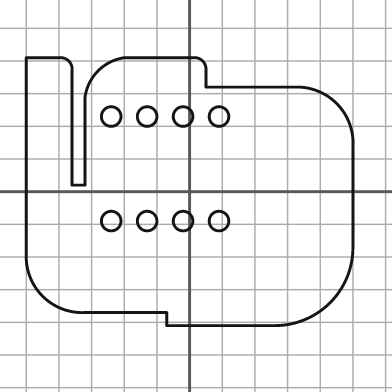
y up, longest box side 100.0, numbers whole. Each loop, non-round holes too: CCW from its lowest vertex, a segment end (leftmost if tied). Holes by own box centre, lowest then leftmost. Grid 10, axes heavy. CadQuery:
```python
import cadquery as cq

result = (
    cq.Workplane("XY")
    .moveTo(-7.0, -41.0)
    .lineTo(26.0, -41.0)
    .threePointArc((43.0, -34.0), (50.0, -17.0))
    .lineTo(50.0, 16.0)
    .threePointArc((45.0, 27.0), (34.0, 32.0))
    .lineTo(5.0, 32.0)
    .lineTo(5.0, 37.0)
    .threePointArc((4.0, 40.0), (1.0, 41.0))
    .lineTo(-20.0, 41.0)
    .threePointArc((-28.0, 37.0), (-32.0, 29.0))
    .lineTo(-32.0, 2.0)
    .lineTo(-36.0, 2.0)
    .lineTo(-36.0, 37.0)
    .threePointArc((-37.0, 40.0), (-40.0, 41.0))
    .lineTo(-50.0, 41.0)
    .lineTo(-50.0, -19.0)
    .threePointArc((-45.0, -32.0), (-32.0, -37.0))
    .lineTo(-7.0, -37.0)
    .close()
    .moveTo(-24.0, -9.0)
    .circle(3.0)
    .moveTo(-13.0, -9.0)
    .circle(3.0)
    .moveTo(-2.0, -9.0)
    .circle(3.0)
    .moveTo(9.0, -9.0)
    .circle(3.0)
    .moveTo(-24.0, 23.0)
    .circle(3.0)
    .moveTo(-13.0, 23.0)
    .circle(3.0)
    .moveTo(-2.0, 23.0)
    .circle(3.0)
    .moveTo(9.0, 23.0)
    .circle(3.0)
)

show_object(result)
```